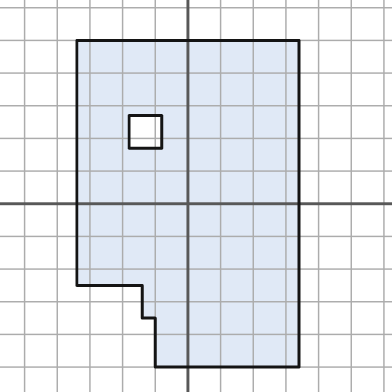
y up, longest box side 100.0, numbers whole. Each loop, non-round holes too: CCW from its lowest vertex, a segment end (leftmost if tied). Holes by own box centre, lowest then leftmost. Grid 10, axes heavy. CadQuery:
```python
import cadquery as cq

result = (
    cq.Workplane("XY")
    .moveTo(-10.0, -50.0)
    .lineTo(34.0, -50.0)
    .lineTo(34.0, 50.0)
    .lineTo(-34.0, 50.0)
    .lineTo(-34.0, -25.0)
    .lineTo(-14.0, -25.0)
    .lineTo(-14.0, -35.0)
    .lineTo(-10.0, -35.0)
    .close()
    .moveTo(-18.0, 17.0)
    .lineTo(-8.0, 17.0)
    .lineTo(-8.0, 27.0)
    .lineTo(-18.0, 27.0)
    .close()
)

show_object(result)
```